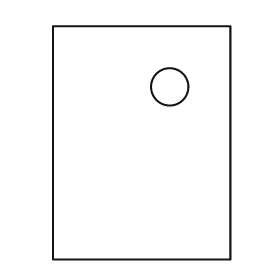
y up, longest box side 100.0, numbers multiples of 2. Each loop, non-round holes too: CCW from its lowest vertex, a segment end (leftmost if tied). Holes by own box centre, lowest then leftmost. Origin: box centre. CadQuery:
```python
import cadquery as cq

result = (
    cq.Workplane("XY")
    .moveTo(-38.0, -50.0)
    .lineTo(38.0, -50.0)
    .lineTo(38.0, 50.0)
    .lineTo(-38.0, 50.0)
    .close()
    .moveTo(12.0, 24.0)
    .circle(8.0)
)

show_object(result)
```